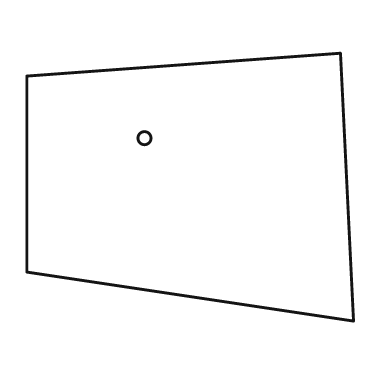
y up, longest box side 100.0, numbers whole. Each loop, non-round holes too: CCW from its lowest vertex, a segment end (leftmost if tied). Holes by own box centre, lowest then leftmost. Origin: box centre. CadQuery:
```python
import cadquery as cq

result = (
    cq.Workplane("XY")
    .moveTo(50.0, -41.0)
    .lineTo(46.0, 41.0)
    .lineTo(-50.0, 34.0)
    .lineTo(-50.0, -26.0)
    .close()
    .moveTo(-14.0, 15.0)
    .circle(2.0)
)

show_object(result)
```